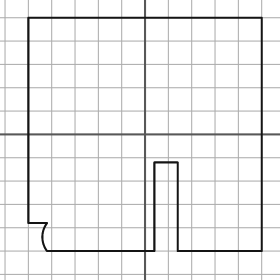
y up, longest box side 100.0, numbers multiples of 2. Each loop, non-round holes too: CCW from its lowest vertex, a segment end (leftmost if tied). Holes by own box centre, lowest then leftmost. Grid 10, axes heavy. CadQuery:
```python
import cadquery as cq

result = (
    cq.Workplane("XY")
    .moveTo(-42.0, -50.0)
    .lineTo(4.0, -50.0)
    .lineTo(4.0, -12.0)
    .lineTo(14.0, -12.0)
    .lineTo(14.0, -50.0)
    .lineTo(50.0, -50.0)
    .lineTo(50.0, 50.0)
    .lineTo(-50.0, 50.0)
    .lineTo(-50.0, -38.0)
    .lineTo(-42.0, -38.0)
    .threePointArc((-44.0, -44.0), (-42.0, -50.0))
    .close()
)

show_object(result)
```